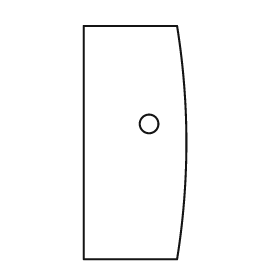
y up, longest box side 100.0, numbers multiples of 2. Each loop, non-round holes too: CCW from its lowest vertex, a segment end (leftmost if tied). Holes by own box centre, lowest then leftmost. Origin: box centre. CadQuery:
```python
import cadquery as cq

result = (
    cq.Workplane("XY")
    .moveTo(-22.0, -50.0)
    .lineTo(18.0, -50.0)
    .threePointArc((22.0, 0.0), (18.0, 50.0))
    .lineTo(-22.0, 50.0)
    .close()
    .moveTo(6.0, 8.0)
    .circle(4.0)
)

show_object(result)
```